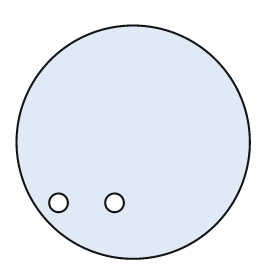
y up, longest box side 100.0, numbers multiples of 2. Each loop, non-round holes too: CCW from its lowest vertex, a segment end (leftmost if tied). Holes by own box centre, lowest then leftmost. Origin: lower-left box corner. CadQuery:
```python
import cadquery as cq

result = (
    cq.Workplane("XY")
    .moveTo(50.0, 50.0)
    .circle(50.0)
    .moveTo(18.0, 24.0)
    .circle(4.0)
    .moveTo(42.0, 24.0)
    .circle(4.0)
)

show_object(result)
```